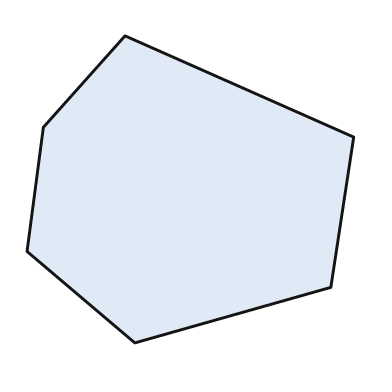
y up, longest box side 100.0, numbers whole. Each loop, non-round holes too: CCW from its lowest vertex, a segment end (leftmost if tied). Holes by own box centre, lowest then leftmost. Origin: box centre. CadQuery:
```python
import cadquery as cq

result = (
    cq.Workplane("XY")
    .moveTo(-17.0, -47.0)
    .lineTo(43.0, -30.0)
    .lineTo(50.0, 16.0)
    .lineTo(-20.0, 47.0)
    .lineTo(-45.0, 19.0)
    .lineTo(-50.0, -19.0)
    .close()
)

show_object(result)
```